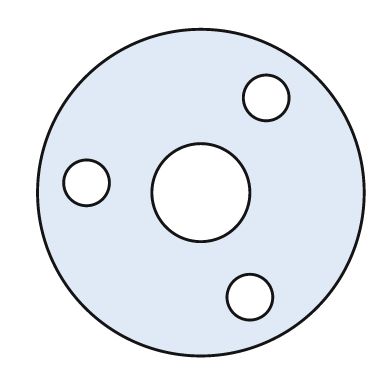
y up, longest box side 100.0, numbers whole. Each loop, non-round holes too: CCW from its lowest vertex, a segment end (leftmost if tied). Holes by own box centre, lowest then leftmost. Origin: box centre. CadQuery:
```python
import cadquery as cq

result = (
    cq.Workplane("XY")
    .moveTo(0.0, 0.0)
    .circle(50.0)
    .moveTo(15.0, -32.0)
    .circle(7.0)
    .moveTo(0.0, 0.0)
    .circle(15.0)
    .moveTo(-35.0, 3.0)
    .circle(7.0)
    .moveTo(20.0, 29.0)
    .circle(7.0)
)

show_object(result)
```